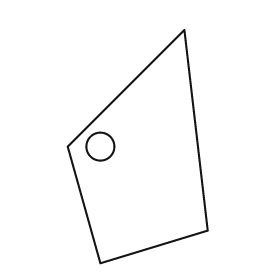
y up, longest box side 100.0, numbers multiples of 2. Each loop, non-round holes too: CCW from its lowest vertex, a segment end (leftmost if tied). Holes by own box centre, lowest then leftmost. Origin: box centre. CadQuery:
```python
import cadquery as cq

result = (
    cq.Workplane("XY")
    .moveTo(-16.0, -50.0)
    .lineTo(30.0, -36.0)
    .lineTo(20.0, 50.0)
    .lineTo(-30.0, 0.0)
    .close()
    .moveTo(-16.0, 0.0)
    .circle(6.0)
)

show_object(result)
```